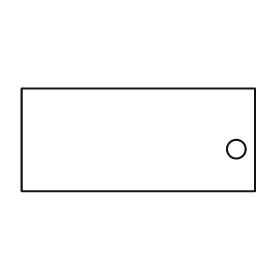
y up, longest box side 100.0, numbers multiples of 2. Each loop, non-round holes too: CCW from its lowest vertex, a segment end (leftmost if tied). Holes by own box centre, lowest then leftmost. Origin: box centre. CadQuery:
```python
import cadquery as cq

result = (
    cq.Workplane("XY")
    .moveTo(-50.0, -22.0)
    .lineTo(50.0, -22.0)
    .lineTo(50.0, 22.0)
    .lineTo(-50.0, 22.0)
    .close()
    .moveTo(42.0, -4.0)
    .circle(4.0)
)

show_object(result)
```